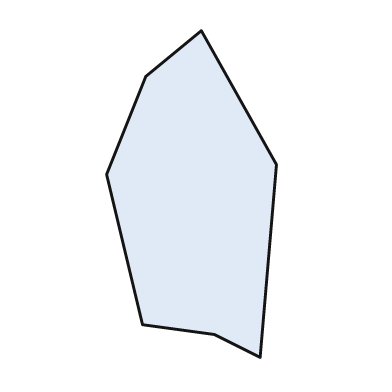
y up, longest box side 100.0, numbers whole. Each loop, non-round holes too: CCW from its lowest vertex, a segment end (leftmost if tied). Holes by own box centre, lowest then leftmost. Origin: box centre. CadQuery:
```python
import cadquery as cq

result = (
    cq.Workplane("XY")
    .moveTo(21.0, -50.0)
    .lineTo(26.0, 9.0)
    .lineTo(3.0, 50.0)
    .lineTo(-14.0, 36.0)
    .lineTo(-26.0, 6.0)
    .lineTo(-15.0, -40.0)
    .lineTo(7.0, -43.0)
    .close()
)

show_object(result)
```